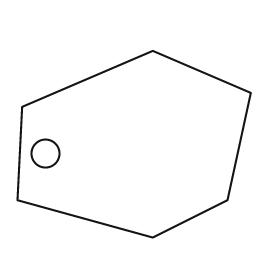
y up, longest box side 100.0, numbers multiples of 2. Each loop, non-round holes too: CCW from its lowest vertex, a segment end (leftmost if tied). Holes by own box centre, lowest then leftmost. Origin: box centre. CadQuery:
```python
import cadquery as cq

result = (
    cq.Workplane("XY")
    .moveTo(8.0, -40.0)
    .lineTo(40.0, -24.0)
    .lineTo(50.0, 22.0)
    .lineTo(8.0, 40.0)
    .lineTo(-48.0, 16.0)
    .lineTo(-50.0, -24.0)
    .close()
    .moveTo(-38.0, -4.0)
    .circle(6.0)
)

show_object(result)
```